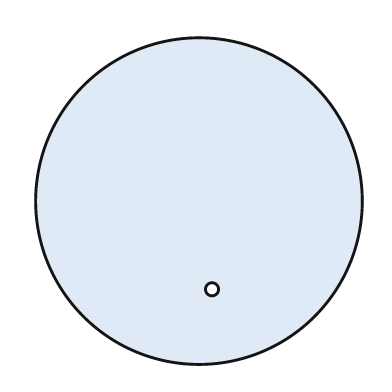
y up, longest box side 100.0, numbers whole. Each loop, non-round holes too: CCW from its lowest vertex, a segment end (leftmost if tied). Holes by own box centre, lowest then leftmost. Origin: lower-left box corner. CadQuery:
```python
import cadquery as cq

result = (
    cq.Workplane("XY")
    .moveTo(50.0, 50.0)
    .circle(50.0)
    .moveTo(54.0, 23.0)
    .circle(2.0)
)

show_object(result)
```